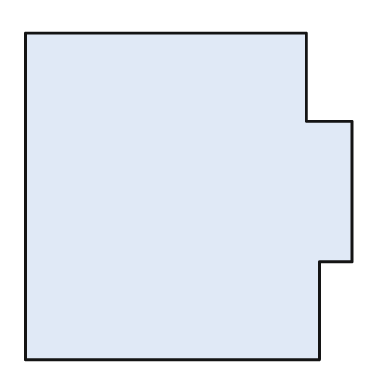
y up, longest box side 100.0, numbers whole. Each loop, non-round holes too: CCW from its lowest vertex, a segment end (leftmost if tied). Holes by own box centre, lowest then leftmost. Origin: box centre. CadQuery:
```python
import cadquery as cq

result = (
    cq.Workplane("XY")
    .moveTo(-50.0, -50.0)
    .lineTo(40.0, -50.0)
    .lineTo(40.0, -20.0)
    .lineTo(50.0, -20.0)
    .lineTo(50.0, 23.0)
    .lineTo(36.0, 23.0)
    .lineTo(36.0, 50.0)
    .lineTo(-50.0, 50.0)
    .close()
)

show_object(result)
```